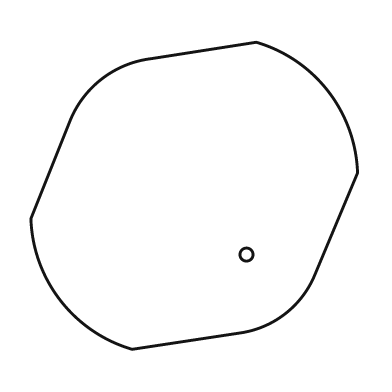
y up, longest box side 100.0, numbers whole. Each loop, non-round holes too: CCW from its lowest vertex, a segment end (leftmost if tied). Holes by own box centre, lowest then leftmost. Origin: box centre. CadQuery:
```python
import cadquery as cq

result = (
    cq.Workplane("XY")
    .moveTo(-19.0, -47.0)
    .lineTo(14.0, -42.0)
    .threePointArc((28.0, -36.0), (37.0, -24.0))
    .lineTo(50.0, 7.0)
    .threePointArc((41.0, 32.0), (19.0, 47.0))
    .lineTo(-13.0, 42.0)
    .threePointArc((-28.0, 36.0), (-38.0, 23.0))
    .lineTo(-50.0, -7.0)
    .threePointArc((-41.0, -32.0), (-19.0, -47.0))
    .close()
    .moveTo(16.0, -18.0)
    .circle(2.0)
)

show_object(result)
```